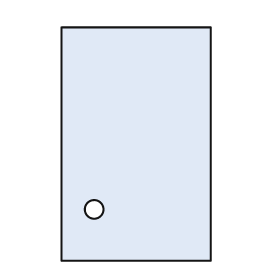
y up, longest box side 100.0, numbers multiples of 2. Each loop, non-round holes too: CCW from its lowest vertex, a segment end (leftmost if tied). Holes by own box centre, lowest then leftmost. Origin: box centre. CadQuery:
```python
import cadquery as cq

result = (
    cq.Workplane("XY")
    .moveTo(-32.0, -50.0)
    .lineTo(32.0, -50.0)
    .lineTo(32.0, 50.0)
    .lineTo(-32.0, 50.0)
    .close()
    .moveTo(-18.0, -28.0)
    .circle(4.0)
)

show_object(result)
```